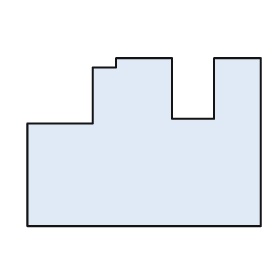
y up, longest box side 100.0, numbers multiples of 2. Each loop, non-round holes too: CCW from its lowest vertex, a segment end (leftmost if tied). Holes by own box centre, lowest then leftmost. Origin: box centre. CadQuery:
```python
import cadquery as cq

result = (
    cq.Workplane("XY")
    .moveTo(-50.0, -36.0)
    .lineTo(50.0, -36.0)
    .lineTo(50.0, 36.0)
    .lineTo(30.0, 36.0)
    .lineTo(30.0, 10.0)
    .lineTo(12.0, 10.0)
    .lineTo(12.0, 36.0)
    .lineTo(-12.0, 36.0)
    .lineTo(-12.0, 32.0)
    .lineTo(-22.0, 32.0)
    .lineTo(-22.0, 8.0)
    .lineTo(-50.0, 8.0)
    .close()
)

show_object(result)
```